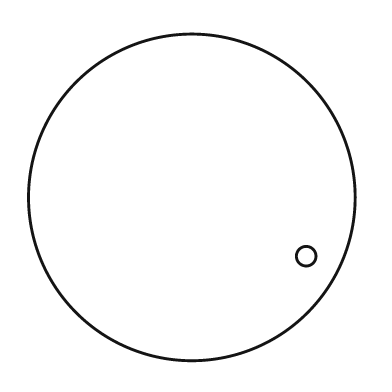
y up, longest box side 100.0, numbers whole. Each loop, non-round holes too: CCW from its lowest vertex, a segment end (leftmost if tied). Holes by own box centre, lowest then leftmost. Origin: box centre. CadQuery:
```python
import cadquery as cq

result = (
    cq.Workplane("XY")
    .moveTo(0.0, 0.0)
    .circle(50.0)
    .moveTo(35.0, -18.0)
    .circle(3.0)
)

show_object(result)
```